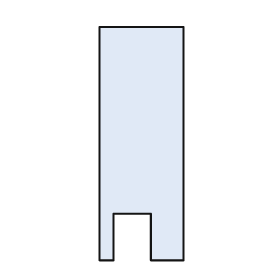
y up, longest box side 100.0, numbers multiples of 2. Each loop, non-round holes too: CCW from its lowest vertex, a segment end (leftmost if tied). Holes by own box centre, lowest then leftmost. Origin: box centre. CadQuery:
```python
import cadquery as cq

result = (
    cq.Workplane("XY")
    .moveTo(-18.0, -50.0)
    .lineTo(-12.0, -50.0)
    .lineTo(-12.0, -30.0)
    .lineTo(4.0, -30.0)
    .lineTo(4.0, -50.0)
    .lineTo(18.0, -50.0)
    .lineTo(18.0, 50.0)
    .lineTo(-18.0, 50.0)
    .close()
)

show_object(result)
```